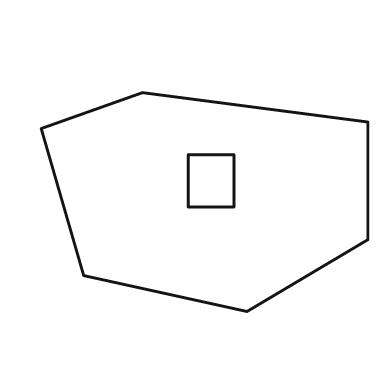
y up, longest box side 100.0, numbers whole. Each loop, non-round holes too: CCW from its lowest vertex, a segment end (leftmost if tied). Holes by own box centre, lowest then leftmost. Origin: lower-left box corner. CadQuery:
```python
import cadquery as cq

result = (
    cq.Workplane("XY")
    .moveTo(63.0, 0.0)
    .lineTo(100.0, 22.0)
    .lineTo(100.0, 58.0)
    .lineTo(31.0, 67.0)
    .lineTo(0.0, 56.0)
    .lineTo(13.0, 11.0)
    .close()
    .moveTo(45.0, 32.0)
    .lineTo(59.0, 32.0)
    .lineTo(59.0, 48.0)
    .lineTo(45.0, 48.0)
    .close()
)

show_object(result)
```